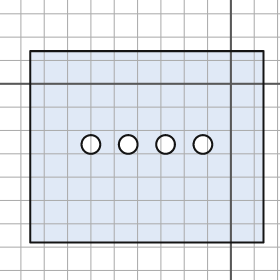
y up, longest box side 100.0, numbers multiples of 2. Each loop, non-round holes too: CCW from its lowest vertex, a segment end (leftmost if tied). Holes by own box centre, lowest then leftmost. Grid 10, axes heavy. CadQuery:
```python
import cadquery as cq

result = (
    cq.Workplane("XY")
    .moveTo(-86.0, -68.0)
    .lineTo(14.0, -68.0)
    .lineTo(14.0, 14.0)
    .lineTo(-86.0, 14.0)
    .close()
    .moveTo(-60.0, -26.0)
    .circle(4.0)
    .moveTo(-44.0, -26.0)
    .circle(4.0)
    .moveTo(-28.0, -26.0)
    .circle(4.0)
    .moveTo(-12.0, -26.0)
    .circle(4.0)
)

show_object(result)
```